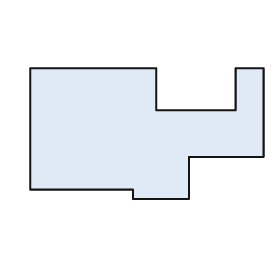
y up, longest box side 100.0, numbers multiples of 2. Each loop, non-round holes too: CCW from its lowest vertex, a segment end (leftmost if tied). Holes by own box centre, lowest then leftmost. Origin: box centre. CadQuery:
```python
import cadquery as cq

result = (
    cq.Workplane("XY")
    .moveTo(-6.0, -28.0)
    .lineTo(18.0, -28.0)
    .lineTo(18.0, -10.0)
    .lineTo(50.0, -10.0)
    .lineTo(50.0, 28.0)
    .lineTo(38.0, 28.0)
    .lineTo(38.0, 10.0)
    .lineTo(4.0, 10.0)
    .lineTo(4.0, 28.0)
    .lineTo(-50.0, 28.0)
    .lineTo(-50.0, -24.0)
    .lineTo(-6.0, -24.0)
    .close()
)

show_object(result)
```